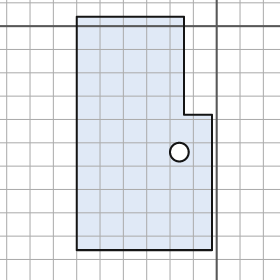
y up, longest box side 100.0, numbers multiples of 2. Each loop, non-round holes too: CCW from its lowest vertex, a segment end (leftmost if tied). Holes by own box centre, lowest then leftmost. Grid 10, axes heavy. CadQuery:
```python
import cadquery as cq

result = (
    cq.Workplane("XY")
    .moveTo(-60.0, -96.0)
    .lineTo(-2.0, -96.0)
    .lineTo(-2.0, -38.0)
    .lineTo(-14.0, -38.0)
    .lineTo(-14.0, 4.0)
    .lineTo(-60.0, 4.0)
    .close()
    .moveTo(-16.0, -54.0)
    .circle(4.0)
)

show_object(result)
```